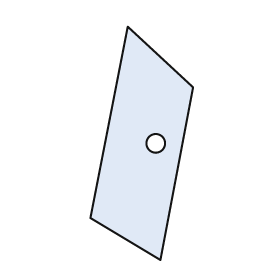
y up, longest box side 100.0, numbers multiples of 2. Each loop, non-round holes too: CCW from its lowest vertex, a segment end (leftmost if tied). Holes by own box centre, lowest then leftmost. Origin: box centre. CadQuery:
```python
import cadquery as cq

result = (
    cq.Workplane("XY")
    .moveTo(8.0, -50.0)
    .lineTo(22.0, 24.0)
    .lineTo(-6.0, 50.0)
    .lineTo(-22.0, -32.0)
    .close()
    .moveTo(6.0, 0.0)
    .circle(4.0)
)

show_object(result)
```